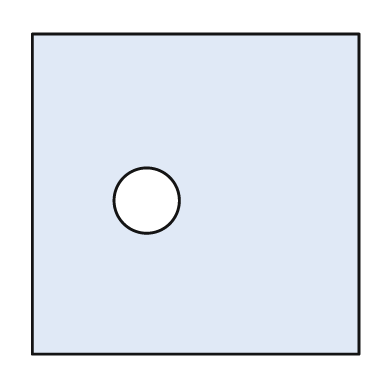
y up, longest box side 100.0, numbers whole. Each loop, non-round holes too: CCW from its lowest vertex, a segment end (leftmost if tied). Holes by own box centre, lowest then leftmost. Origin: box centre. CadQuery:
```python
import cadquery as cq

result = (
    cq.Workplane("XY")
    .moveTo(-50.0, -49.0)
    .lineTo(50.0, -49.0)
    .lineTo(50.0, 49.0)
    .lineTo(-50.0, 49.0)
    .close()
    .moveTo(-15.0, -2.0)
    .circle(10.0)
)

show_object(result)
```